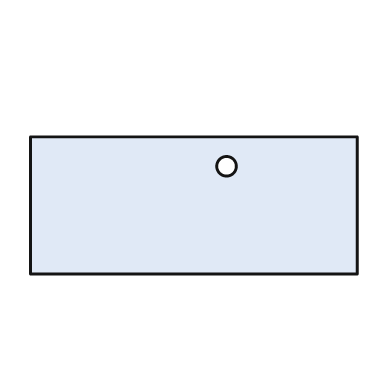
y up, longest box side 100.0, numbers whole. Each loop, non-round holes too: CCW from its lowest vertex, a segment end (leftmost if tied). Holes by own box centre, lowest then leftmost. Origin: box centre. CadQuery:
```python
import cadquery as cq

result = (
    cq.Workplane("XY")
    .moveTo(-50.0, -21.0)
    .lineTo(50.0, -21.0)
    .lineTo(50.0, 21.0)
    .lineTo(-50.0, 21.0)
    .close()
    .moveTo(10.0, 12.0)
    .circle(3.0)
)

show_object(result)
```